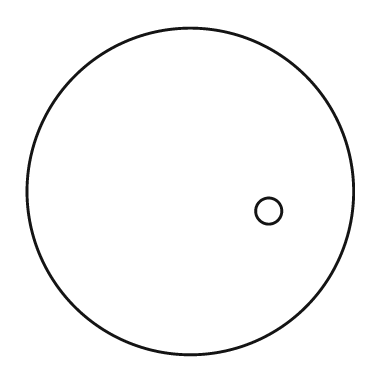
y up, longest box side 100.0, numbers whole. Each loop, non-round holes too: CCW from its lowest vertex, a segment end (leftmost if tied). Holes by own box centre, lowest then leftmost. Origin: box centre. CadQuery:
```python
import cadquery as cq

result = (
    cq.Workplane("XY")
    .moveTo(0.0, 0.0)
    .circle(50.0)
    .moveTo(24.0, -6.0)
    .circle(4.0)
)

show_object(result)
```